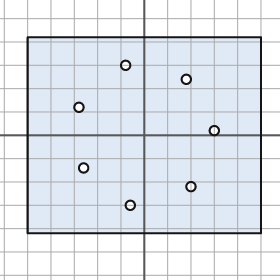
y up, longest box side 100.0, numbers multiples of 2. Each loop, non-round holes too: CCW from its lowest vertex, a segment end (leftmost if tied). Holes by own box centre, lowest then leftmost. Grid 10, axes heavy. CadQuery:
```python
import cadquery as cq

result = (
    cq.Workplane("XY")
    .moveTo(-50.0, -42.0)
    .lineTo(50.0, -42.0)
    .lineTo(50.0, 42.0)
    .lineTo(-50.0, 42.0)
    .close()
    .moveTo(-6.0, -30.0)
    .circle(2.0)
    .moveTo(20.0, -22.0)
    .circle(2.0)
    .moveTo(-26.0, -14.0)
    .circle(2.0)
    .moveTo(30.0, 2.0)
    .circle(2.0)
    .moveTo(-28.0, 12.0)
    .circle(2.0)
    .moveTo(18.0, 24.0)
    .circle(2.0)
    .moveTo(-8.0, 30.0)
    .circle(2.0)
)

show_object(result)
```